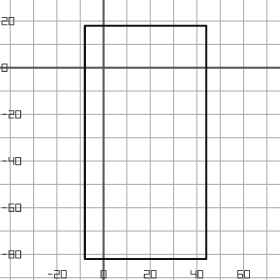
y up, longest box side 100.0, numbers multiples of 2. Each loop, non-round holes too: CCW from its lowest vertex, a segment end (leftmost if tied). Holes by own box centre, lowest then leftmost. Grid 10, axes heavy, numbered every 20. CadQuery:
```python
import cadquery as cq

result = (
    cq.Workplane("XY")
    .moveTo(-8.0, -82.0)
    .lineTo(44.0, -82.0)
    .lineTo(44.0, 18.0)
    .lineTo(-8.0, 18.0)
    .close()
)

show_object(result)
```